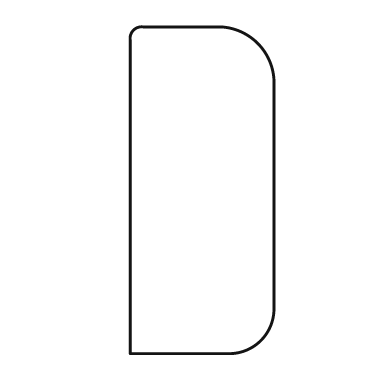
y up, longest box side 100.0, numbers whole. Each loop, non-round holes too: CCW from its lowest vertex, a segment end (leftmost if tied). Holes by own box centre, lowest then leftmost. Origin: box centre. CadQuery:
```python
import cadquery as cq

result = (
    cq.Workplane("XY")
    .moveTo(-22.0, -50.0)
    .lineTo(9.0, -50.0)
    .threePointArc((18.0, -46.0), (22.0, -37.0))
    .lineTo(22.0, 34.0)
    .threePointArc((17.0, 45.0), (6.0, 50.0))
    .lineTo(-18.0, 50.0)
    .threePointArc((-21.0, 49.0), (-22.0, 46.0))
    .close()
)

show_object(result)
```